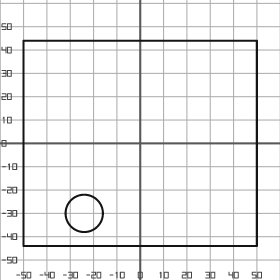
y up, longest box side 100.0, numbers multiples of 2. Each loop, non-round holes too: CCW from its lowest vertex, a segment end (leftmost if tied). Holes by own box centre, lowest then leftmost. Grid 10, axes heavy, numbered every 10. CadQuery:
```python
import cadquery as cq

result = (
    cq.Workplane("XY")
    .moveTo(-50.0, -44.0)
    .lineTo(50.0, -44.0)
    .lineTo(50.0, 44.0)
    .lineTo(-50.0, 44.0)
    .close()
    .moveTo(-24.0, -30.0)
    .circle(8.0)
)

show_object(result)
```